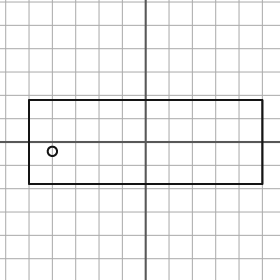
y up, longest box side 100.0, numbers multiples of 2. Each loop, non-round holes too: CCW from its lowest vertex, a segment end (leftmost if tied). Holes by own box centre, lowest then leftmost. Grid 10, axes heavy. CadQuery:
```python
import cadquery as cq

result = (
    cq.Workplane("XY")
    .moveTo(-50.0, -18.0)
    .lineTo(50.0, -18.0)
    .lineTo(50.0, 18.0)
    .lineTo(-50.0, 18.0)
    .close()
    .moveTo(-40.0, -4.0)
    .circle(2.0)
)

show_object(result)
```